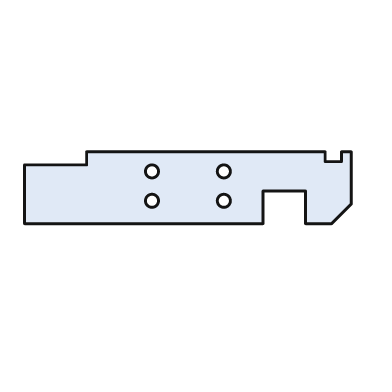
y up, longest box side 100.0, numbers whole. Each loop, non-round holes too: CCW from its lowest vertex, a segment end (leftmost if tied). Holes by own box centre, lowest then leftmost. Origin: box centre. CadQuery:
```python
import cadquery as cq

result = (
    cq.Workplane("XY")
    .moveTo(-50.0, -11.0)
    .lineTo(23.0, -11.0)
    .lineTo(23.0, -1.0)
    .lineTo(36.0, -1.0)
    .lineTo(36.0, -11.0)
    .lineTo(44.0, -11.0)
    .lineTo(50.0, -5.0)
    .lineTo(50.0, 11.0)
    .lineTo(47.0, 11.0)
    .lineTo(47.0, 8.0)
    .lineTo(42.0, 8.0)
    .lineTo(42.0, 11.0)
    .lineTo(-31.0, 11.0)
    .lineTo(-31.0, 7.0)
    .lineTo(-50.0, 7.0)
    .close()
    .moveTo(-11.0, -4.0)
    .circle(2.0)
    .moveTo(11.0, -4.0)
    .circle(2.0)
    .moveTo(-11.0, 5.0)
    .circle(2.0)
    .moveTo(11.0, 5.0)
    .circle(2.0)
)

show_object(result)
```